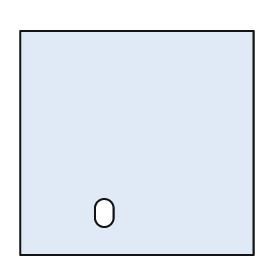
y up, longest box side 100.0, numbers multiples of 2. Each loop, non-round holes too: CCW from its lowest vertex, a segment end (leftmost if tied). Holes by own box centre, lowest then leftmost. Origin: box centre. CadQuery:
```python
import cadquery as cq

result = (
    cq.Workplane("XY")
    .moveTo(-50.0, -48.0)
    .lineTo(50.0, -48.0)
    .lineTo(50.0, 48.0)
    .lineTo(-50.0, 48.0)
    .close()
    .moveTo(-18.0, -32.0)
    .threePointArc((-14.0, -36.0), (-10.0, -32.0))
    .lineTo(-10.0, -28.0)
    .threePointArc((-14.0, -24.0), (-18.0, -28.0))
    .close()
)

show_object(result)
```